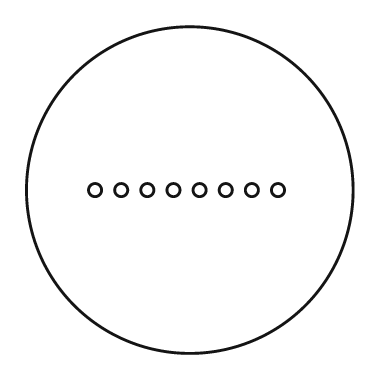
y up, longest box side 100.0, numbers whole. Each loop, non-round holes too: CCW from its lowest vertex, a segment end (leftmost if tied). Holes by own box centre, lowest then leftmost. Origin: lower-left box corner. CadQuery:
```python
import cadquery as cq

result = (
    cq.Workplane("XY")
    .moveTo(50.0, 50.0)
    .circle(50.0)
    .moveTo(21.0, 50.0)
    .circle(2.0)
    .moveTo(29.0, 50.0)
    .circle(2.0)
    .moveTo(37.0, 50.0)
    .circle(2.0)
    .moveTo(45.0, 50.0)
    .circle(2.0)
    .moveTo(53.0, 50.0)
    .circle(2.0)
    .moveTo(61.0, 50.0)
    .circle(2.0)
    .moveTo(69.0, 50.0)
    .circle(2.0)
    .moveTo(77.0, 50.0)
    .circle(2.0)
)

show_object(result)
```